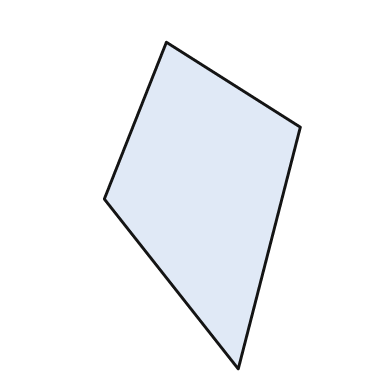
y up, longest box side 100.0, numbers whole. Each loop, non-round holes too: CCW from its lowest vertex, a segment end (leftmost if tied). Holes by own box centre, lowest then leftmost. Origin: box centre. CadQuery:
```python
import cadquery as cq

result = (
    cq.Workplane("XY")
    .moveTo(11.0, -50.0)
    .lineTo(30.0, 24.0)
    .lineTo(-11.0, 50.0)
    .lineTo(-30.0, 2.0)
    .close()
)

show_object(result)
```